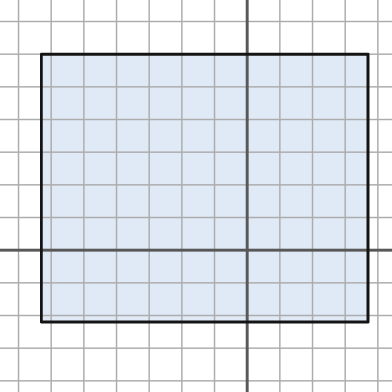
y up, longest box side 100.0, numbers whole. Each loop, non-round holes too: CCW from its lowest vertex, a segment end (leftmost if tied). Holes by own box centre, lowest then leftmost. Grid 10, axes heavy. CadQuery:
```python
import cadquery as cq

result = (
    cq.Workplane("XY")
    .moveTo(-63.0, -22.0)
    .lineTo(37.0, -22.0)
    .lineTo(37.0, 60.0)
    .lineTo(-63.0, 60.0)
    .close()
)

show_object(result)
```